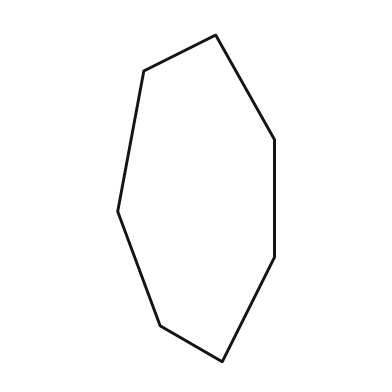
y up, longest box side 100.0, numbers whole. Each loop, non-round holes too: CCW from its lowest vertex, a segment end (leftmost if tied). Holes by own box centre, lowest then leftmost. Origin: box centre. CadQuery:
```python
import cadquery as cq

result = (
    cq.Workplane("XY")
    .moveTo(8.0, -50.0)
    .lineTo(24.0, -18.0)
    .lineTo(24.0, 18.0)
    .lineTo(6.0, 50.0)
    .lineTo(-16.0, 39.0)
    .lineTo(-24.0, -4.0)
    .lineTo(-11.0, -39.0)
    .close()
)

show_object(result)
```